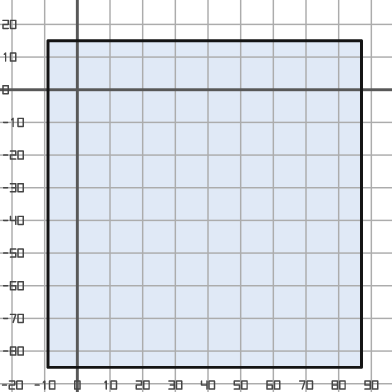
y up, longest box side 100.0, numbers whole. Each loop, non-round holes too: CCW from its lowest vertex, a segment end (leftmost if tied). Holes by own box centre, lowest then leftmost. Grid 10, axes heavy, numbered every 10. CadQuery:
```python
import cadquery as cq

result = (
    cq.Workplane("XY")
    .moveTo(-9.0, -85.0)
    .lineTo(87.0, -85.0)
    .lineTo(87.0, 15.0)
    .lineTo(-9.0, 15.0)
    .close()
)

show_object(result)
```